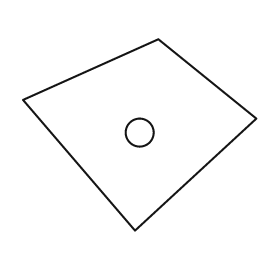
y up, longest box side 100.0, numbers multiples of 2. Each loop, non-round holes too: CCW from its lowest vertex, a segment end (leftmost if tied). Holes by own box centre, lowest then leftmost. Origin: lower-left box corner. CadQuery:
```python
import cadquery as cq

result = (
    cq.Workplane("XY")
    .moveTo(48.0, 0.0)
    .lineTo(100.0, 48.0)
    .lineTo(58.0, 82.0)
    .lineTo(0.0, 56.0)
    .close()
    .moveTo(50.0, 42.0)
    .circle(6.0)
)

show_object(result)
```